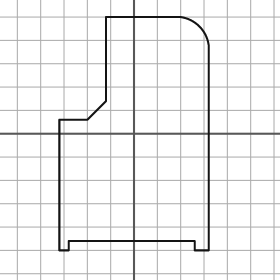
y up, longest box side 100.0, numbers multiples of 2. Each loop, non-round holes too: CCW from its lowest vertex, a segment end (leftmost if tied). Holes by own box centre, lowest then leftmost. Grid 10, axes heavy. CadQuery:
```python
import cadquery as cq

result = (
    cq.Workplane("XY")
    .moveTo(-32.0, -50.0)
    .lineTo(-28.0, -50.0)
    .lineTo(-28.0, -46.0)
    .lineTo(26.0, -46.0)
    .lineTo(26.0, -50.0)
    .lineTo(32.0, -50.0)
    .lineTo(32.0, 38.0)
    .threePointArc((28.0, 46.0), (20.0, 50.0))
    .lineTo(-12.0, 50.0)
    .lineTo(-12.0, 14.0)
    .lineTo(-20.0, 6.0)
    .lineTo(-32.0, 6.0)
    .close()
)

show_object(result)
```